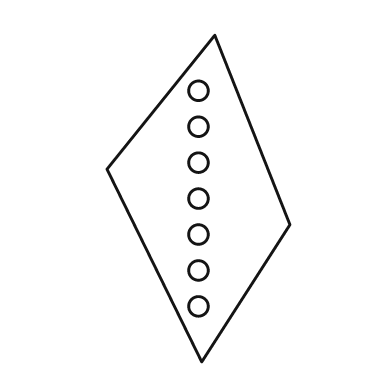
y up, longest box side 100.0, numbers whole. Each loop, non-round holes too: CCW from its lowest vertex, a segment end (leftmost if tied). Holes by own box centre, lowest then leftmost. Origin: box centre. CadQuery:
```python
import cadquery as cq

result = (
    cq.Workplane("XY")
    .moveTo(1.0, -50.0)
    .lineTo(28.0, -8.0)
    .lineTo(5.0, 50.0)
    .lineTo(-28.0, 9.0)
    .close()
    .moveTo(0.0, -33.0)
    .circle(3.0)
    .moveTo(0.0, -22.0)
    .circle(3.0)
    .moveTo(0.0, -11.0)
    .circle(3.0)
    .moveTo(0.0, 0.0)
    .circle(3.0)
    .moveTo(0.0, 11.0)
    .circle(3.0)
    .moveTo(0.0, 22.0)
    .circle(3.0)
    .moveTo(0.0, 33.0)
    .circle(3.0)
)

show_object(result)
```